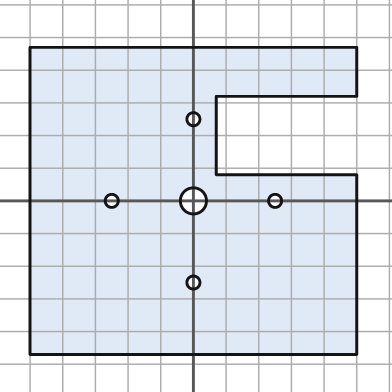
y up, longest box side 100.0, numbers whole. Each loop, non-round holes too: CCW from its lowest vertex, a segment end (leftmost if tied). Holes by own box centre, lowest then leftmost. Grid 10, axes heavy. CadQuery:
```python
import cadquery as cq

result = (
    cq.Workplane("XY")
    .moveTo(-50.0, -47.0)
    .lineTo(50.0, -47.0)
    .lineTo(50.0, 8.0)
    .lineTo(7.0, 8.0)
    .lineTo(7.0, 32.0)
    .lineTo(50.0, 32.0)
    .lineTo(50.0, 47.0)
    .lineTo(-50.0, 47.0)
    .close()
    .moveTo(0.0, -25.0)
    .circle(2.0)
    .moveTo(-25.0, 0.0)
    .circle(2.0)
    .moveTo(0.0, 0.0)
    .circle(4.0)
    .moveTo(25.0, 0.0)
    .circle(2.0)
    .moveTo(0.0, 25.0)
    .circle(2.0)
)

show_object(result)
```